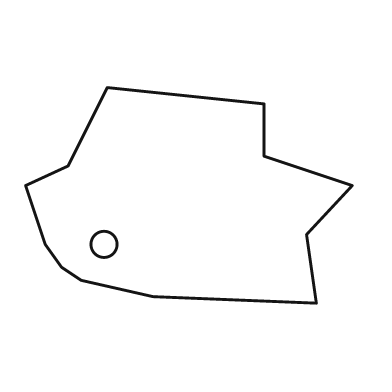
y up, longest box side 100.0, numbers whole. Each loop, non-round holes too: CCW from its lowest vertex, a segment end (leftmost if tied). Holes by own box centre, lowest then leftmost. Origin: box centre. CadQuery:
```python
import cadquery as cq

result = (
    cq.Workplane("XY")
    .moveTo(39.0, -33.0)
    .lineTo(36.0, -12.0)
    .lineTo(50.0, 3.0)
    .lineTo(23.0, 12.0)
    .lineTo(23.0, 28.0)
    .lineTo(-25.0, 33.0)
    .lineTo(-37.0, 9.0)
    .lineTo(-50.0, 3.0)
    .lineTo(-44.0, -15.0)
    .lineTo(-39.0, -22.0)
    .lineTo(-33.0, -26.0)
    .lineTo(-11.0, -31.0)
    .close()
    .moveTo(-26.0, -15.0)
    .circle(4.0)
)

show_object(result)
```